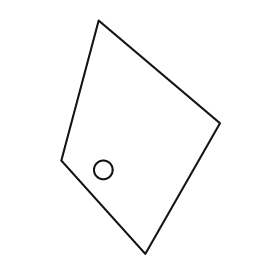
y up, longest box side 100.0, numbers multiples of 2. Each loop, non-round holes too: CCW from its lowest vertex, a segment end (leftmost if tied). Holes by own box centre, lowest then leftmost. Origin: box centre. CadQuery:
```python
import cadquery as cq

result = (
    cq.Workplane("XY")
    .moveTo(2.0, -50.0)
    .lineTo(34.0, 6.0)
    .lineTo(-18.0, 50.0)
    .lineTo(-34.0, -10.0)
    .close()
    .moveTo(-16.0, -14.0)
    .circle(4.0)
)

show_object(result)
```